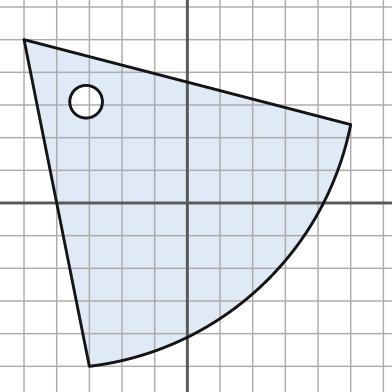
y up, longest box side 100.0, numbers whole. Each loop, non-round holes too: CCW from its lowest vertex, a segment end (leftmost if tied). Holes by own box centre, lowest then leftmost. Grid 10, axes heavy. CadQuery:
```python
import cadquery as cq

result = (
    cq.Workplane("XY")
    .moveTo(-30.0, -50.0)
    .threePointArc((22.0, -26.0), (50.0, 24.0))
    .lineTo(-50.0, 50.0)
    .close()
    .moveTo(-31.0, 31.0)
    .circle(5.0)
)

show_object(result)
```